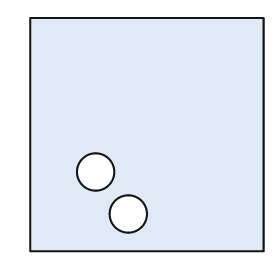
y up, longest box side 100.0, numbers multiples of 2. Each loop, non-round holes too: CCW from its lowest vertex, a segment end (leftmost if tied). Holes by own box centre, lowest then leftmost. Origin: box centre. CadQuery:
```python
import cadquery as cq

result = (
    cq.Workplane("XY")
    .moveTo(-50.0, -50.0)
    .lineTo(50.0, -50.0)
    .lineTo(50.0, 50.0)
    .lineTo(-50.0, 50.0)
    .close()
    .moveTo(-8.0, -34.0)
    .circle(8.0)
    .moveTo(-22.0, -16.0)
    .circle(8.0)
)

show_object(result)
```